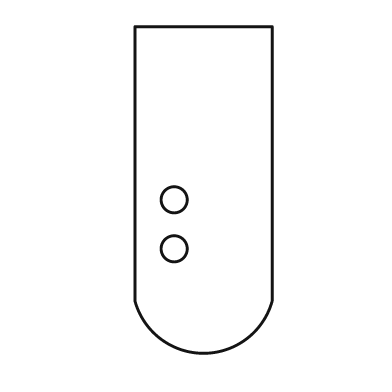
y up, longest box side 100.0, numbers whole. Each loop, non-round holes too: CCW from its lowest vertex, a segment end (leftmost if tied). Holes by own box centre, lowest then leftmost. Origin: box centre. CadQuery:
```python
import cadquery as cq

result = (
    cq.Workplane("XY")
    .moveTo(-21.0, -34.0)
    .threePointArc((0.0, -50.0), (21.0, -34.0))
    .lineTo(21.0, 50.0)
    .lineTo(-21.0, 50.0)
    .close()
    .moveTo(-9.0, -18.0)
    .circle(4.0)
    .moveTo(-9.0, -3.0)
    .circle(4.0)
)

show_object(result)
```